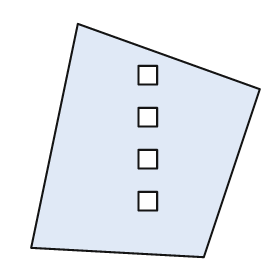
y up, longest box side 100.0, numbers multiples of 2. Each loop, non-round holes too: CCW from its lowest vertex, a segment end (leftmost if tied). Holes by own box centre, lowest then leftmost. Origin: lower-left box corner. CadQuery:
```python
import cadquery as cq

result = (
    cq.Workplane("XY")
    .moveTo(74.0, 0.0)
    .lineTo(98.0, 72.0)
    .lineTo(20.0, 100.0)
    .lineTo(0.0, 4.0)
    .close()
    .moveTo(46.0, 20.0)
    .lineTo(54.0, 20.0)
    .lineTo(54.0, 28.0)
    .lineTo(46.0, 28.0)
    .close()
    .moveTo(46.0, 38.0)
    .lineTo(54.0, 38.0)
    .lineTo(54.0, 46.0)
    .lineTo(46.0, 46.0)
    .close()
    .moveTo(46.0, 56.0)
    .lineTo(54.0, 56.0)
    .lineTo(54.0, 64.0)
    .lineTo(46.0, 64.0)
    .close()
    .moveTo(46.0, 74.0)
    .lineTo(54.0, 74.0)
    .lineTo(54.0, 82.0)
    .lineTo(46.0, 82.0)
    .close()
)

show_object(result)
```